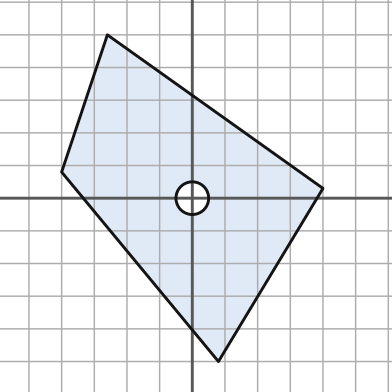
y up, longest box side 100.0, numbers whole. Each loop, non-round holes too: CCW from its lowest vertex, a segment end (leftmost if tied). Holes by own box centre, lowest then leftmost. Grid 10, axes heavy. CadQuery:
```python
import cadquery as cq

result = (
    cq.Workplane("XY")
    .moveTo(8.0, -50.0)
    .lineTo(40.0, 3.0)
    .lineTo(-26.0, 50.0)
    .lineTo(-40.0, 8.0)
    .close()
    .moveTo(0.0, 0.0)
    .circle(5.0)
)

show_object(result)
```